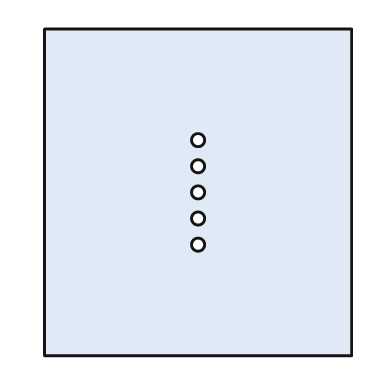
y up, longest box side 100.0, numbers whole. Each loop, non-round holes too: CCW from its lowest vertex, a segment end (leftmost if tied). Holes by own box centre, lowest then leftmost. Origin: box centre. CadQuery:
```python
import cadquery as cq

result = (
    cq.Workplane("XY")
    .moveTo(-47.0, -50.0)
    .lineTo(47.0, -50.0)
    .lineTo(47.0, 50.0)
    .lineTo(-47.0, 50.0)
    .close()
    .moveTo(0.0, -16.0)
    .circle(2.0)
    .moveTo(0.0, -8.0)
    .circle(2.0)
    .moveTo(0.0, 0.0)
    .circle(2.0)
    .moveTo(0.0, 8.0)
    .circle(2.0)
    .moveTo(0.0, 16.0)
    .circle(2.0)
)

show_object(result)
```